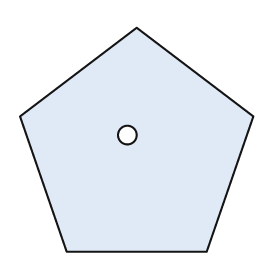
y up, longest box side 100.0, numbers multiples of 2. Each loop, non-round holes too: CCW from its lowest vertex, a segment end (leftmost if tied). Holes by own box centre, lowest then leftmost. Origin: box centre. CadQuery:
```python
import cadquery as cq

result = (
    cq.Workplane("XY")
    .moveTo(-30.0, -48.0)
    .lineTo(30.0, -48.0)
    .lineTo(50.0, 10.0)
    .lineTo(0.0, 48.0)
    .lineTo(-50.0, 10.0)
    .close()
    .moveTo(-4.0, 2.0)
    .circle(4.0)
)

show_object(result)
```